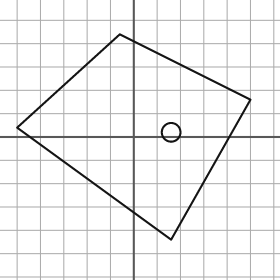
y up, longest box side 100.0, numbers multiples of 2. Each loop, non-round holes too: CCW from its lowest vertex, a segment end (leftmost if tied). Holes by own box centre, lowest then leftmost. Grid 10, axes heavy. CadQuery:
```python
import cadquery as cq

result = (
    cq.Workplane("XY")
    .moveTo(16.0, -44.0)
    .lineTo(50.0, 16.0)
    .lineTo(-6.0, 44.0)
    .lineTo(-50.0, 4.0)
    .close()
    .moveTo(16.0, 2.0)
    .circle(4.0)
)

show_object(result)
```